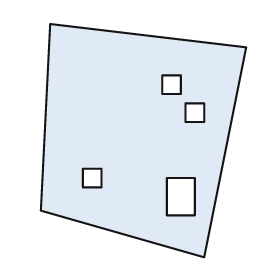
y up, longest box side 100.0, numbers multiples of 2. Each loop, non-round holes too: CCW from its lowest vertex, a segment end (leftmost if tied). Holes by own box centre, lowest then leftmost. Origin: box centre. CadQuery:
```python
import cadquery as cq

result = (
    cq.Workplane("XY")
    .moveTo(26.0, -50.0)
    .lineTo(44.0, 40.0)
    .lineTo(-40.0, 50.0)
    .lineTo(-44.0, -30.0)
    .close()
    .moveTo(10.0, -32.0)
    .lineTo(22.0, -32.0)
    .lineTo(22.0, -16.0)
    .lineTo(10.0, -16.0)
    .close()
    .moveTo(-26.0, -20.0)
    .lineTo(-18.0, -20.0)
    .lineTo(-18.0, -12.0)
    .lineTo(-26.0, -12.0)
    .close()
    .moveTo(18.0, 8.0)
    .lineTo(26.0, 8.0)
    .lineTo(26.0, 16.0)
    .lineTo(18.0, 16.0)
    .close()
    .moveTo(8.0, 20.0)
    .lineTo(16.0, 20.0)
    .lineTo(16.0, 28.0)
    .lineTo(8.0, 28.0)
    .close()
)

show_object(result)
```